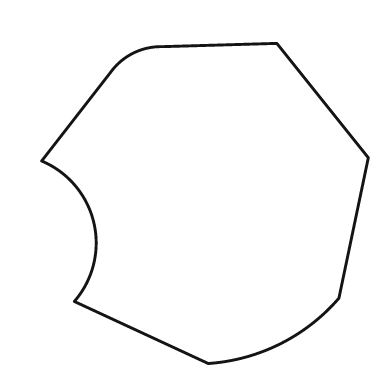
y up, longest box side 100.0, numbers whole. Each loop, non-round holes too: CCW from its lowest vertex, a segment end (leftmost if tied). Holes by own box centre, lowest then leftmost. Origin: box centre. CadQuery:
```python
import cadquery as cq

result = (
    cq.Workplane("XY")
    .moveTo(1.0, -49.0)
    .threePointArc((23.0, -43.0), (41.0, -29.0))
    .lineTo(50.0, 14.0)
    .lineTo(22.0, 49.0)
    .lineTo(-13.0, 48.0)
    .threePointArc((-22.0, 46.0), (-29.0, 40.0))
    .lineTo(-50.0, 13.0)
    .threePointArc((-34.0, -6.0), (-40.0, -30.0))
    .close()
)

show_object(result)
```